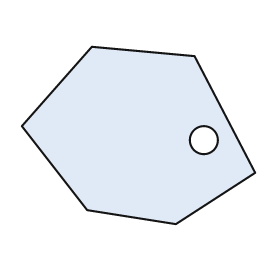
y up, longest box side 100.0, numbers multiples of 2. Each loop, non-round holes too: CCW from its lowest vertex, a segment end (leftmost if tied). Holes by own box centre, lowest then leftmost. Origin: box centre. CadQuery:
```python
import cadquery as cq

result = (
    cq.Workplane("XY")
    .moveTo(16.0, -38.0)
    .lineTo(50.0, -16.0)
    .lineTo(24.0, 34.0)
    .lineTo(-20.0, 38.0)
    .lineTo(-50.0, 4.0)
    .lineTo(-22.0, -32.0)
    .close()
    .moveTo(28.0, -2.0)
    .circle(6.0)
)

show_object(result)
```